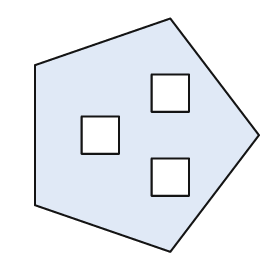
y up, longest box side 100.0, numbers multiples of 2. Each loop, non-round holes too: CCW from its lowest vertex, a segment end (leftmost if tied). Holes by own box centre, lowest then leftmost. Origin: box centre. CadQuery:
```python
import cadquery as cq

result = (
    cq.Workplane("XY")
    .moveTo(10.0, -50.0)
    .lineTo(48.0, 0.0)
    .lineTo(10.0, 50.0)
    .lineTo(-48.0, 30.0)
    .lineTo(-48.0, -30.0)
    .close()
    .moveTo(2.0, -26.0)
    .lineTo(18.0, -26.0)
    .lineTo(18.0, -10.0)
    .lineTo(2.0, -10.0)
    .close()
    .moveTo(-28.0, -8.0)
    .lineTo(-12.0, -8.0)
    .lineTo(-12.0, 8.0)
    .lineTo(-28.0, 8.0)
    .close()
    .moveTo(2.0, 10.0)
    .lineTo(18.0, 10.0)
    .lineTo(18.0, 26.0)
    .lineTo(2.0, 26.0)
    .close()
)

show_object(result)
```